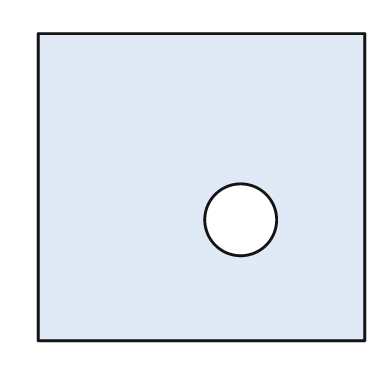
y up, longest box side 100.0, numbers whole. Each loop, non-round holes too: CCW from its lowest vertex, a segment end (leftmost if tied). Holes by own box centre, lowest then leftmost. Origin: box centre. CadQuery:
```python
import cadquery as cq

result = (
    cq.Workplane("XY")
    .moveTo(-50.0, -47.0)
    .lineTo(50.0, -47.0)
    .lineTo(50.0, 47.0)
    .lineTo(-50.0, 47.0)
    .close()
    .moveTo(12.0, -10.0)
    .circle(11.0)
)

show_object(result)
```